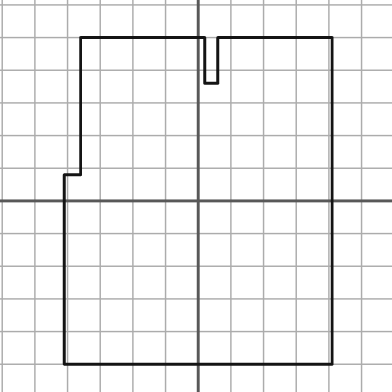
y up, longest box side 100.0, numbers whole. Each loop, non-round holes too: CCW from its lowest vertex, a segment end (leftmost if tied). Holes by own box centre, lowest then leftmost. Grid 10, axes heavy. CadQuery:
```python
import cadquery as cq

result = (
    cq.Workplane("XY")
    .moveTo(-41.0, -50.0)
    .lineTo(41.0, -50.0)
    .lineTo(41.0, 50.0)
    .lineTo(6.0, 50.0)
    .lineTo(6.0, 36.0)
    .lineTo(2.0, 36.0)
    .lineTo(2.0, 50.0)
    .lineTo(-36.0, 50.0)
    .lineTo(-36.0, 8.0)
    .lineTo(-41.0, 8.0)
    .close()
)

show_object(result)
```